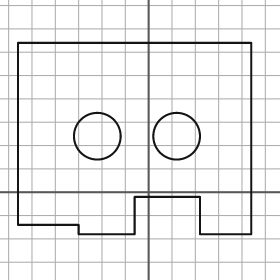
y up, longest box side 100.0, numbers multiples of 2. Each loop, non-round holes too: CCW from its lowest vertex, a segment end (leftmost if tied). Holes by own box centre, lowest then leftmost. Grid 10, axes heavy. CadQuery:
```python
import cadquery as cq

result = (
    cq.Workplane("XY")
    .moveTo(-30.0, -18.0)
    .lineTo(-6.0, -18.0)
    .lineTo(-6.0, -2.0)
    .lineTo(22.0, -2.0)
    .lineTo(22.0, -18.0)
    .lineTo(44.0, -18.0)
    .lineTo(44.0, 64.0)
    .lineTo(-56.0, 64.0)
    .lineTo(-56.0, -14.0)
    .lineTo(-30.0, -14.0)
    .close()
    .moveTo(-22.0, 24.0)
    .circle(10.0)
    .moveTo(12.0, 24.0)
    .circle(10.0)
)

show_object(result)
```